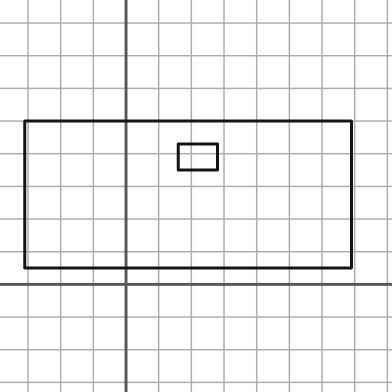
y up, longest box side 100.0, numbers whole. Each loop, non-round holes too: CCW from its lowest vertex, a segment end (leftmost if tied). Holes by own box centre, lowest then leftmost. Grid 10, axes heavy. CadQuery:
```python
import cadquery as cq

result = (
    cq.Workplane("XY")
    .moveTo(-31.0, 5.0)
    .lineTo(69.0, 5.0)
    .lineTo(69.0, 50.0)
    .lineTo(-31.0, 50.0)
    .close()
    .moveTo(16.0, 35.0)
    .lineTo(28.0, 35.0)
    .lineTo(28.0, 43.0)
    .lineTo(16.0, 43.0)
    .close()
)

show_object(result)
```